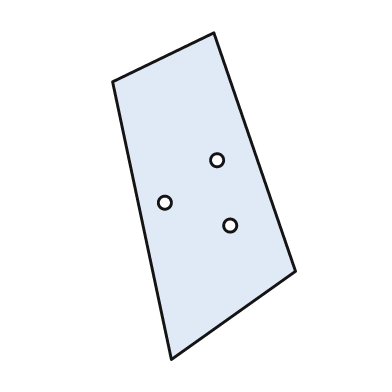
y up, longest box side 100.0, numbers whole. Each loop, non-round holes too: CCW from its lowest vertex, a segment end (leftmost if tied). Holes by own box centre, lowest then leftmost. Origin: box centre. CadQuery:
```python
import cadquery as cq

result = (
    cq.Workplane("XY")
    .moveTo(-10.0, -50.0)
    .lineTo(28.0, -23.0)
    .lineTo(3.0, 50.0)
    .lineTo(-28.0, 35.0)
    .close()
    .moveTo(8.0, -9.0)
    .circle(2.0)
    .moveTo(-12.0, -2.0)
    .circle(2.0)
    .moveTo(4.0, 11.0)
    .circle(2.0)
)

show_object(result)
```